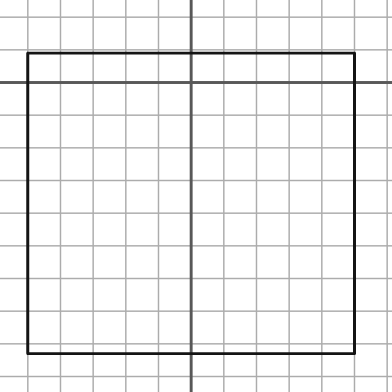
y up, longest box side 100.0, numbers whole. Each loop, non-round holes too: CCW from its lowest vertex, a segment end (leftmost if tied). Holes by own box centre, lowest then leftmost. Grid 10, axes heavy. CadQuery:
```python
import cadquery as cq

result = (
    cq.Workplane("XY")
    .moveTo(-50.0, -83.0)
    .lineTo(50.0, -83.0)
    .lineTo(50.0, 9.0)
    .lineTo(-50.0, 9.0)
    .close()
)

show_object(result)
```